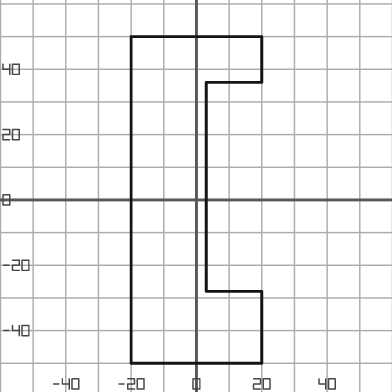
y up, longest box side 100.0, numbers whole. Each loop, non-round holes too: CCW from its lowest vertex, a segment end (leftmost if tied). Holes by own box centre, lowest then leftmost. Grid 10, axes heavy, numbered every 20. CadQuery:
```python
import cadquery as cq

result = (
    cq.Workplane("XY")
    .moveTo(-20.0, -50.0)
    .lineTo(20.0, -50.0)
    .lineTo(20.0, -28.0)
    .lineTo(3.0, -28.0)
    .lineTo(3.0, 36.0)
    .lineTo(20.0, 36.0)
    .lineTo(20.0, 50.0)
    .lineTo(-20.0, 50.0)
    .close()
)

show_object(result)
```